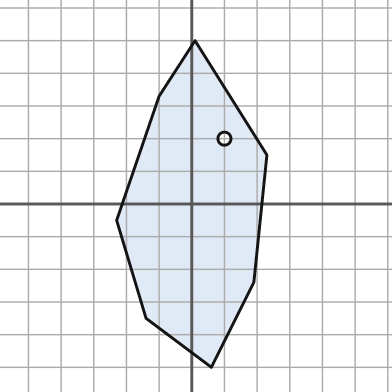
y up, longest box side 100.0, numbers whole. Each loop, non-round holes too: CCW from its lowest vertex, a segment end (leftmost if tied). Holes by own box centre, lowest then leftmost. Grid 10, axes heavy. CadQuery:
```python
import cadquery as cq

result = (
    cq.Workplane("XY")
    .moveTo(6.0, -50.0)
    .lineTo(19.0, -24.0)
    .lineTo(23.0, 15.0)
    .lineTo(1.0, 50.0)
    .lineTo(-10.0, 33.0)
    .lineTo(-23.0, -5.0)
    .lineTo(-14.0, -35.0)
    .close()
    .moveTo(10.0, 20.0)
    .circle(2.0)
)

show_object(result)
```